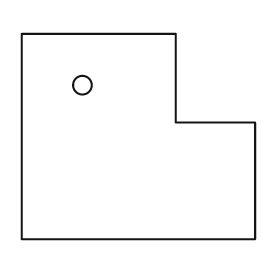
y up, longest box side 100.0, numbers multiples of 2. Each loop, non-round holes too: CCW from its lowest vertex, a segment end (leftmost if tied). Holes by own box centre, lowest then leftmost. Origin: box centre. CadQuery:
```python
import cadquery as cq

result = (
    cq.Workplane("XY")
    .moveTo(-50.0, -44.0)
    .lineTo(50.0, -44.0)
    .lineTo(50.0, 6.0)
    .lineTo(16.0, 6.0)
    .lineTo(16.0, 44.0)
    .lineTo(-50.0, 44.0)
    .close()
    .moveTo(-24.0, 22.0)
    .circle(4.0)
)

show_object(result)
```